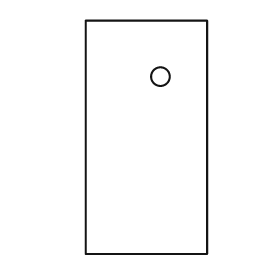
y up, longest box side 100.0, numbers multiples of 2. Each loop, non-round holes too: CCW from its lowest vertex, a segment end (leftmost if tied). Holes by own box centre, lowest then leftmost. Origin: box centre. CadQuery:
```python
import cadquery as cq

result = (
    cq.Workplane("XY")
    .moveTo(-26.0, -50.0)
    .lineTo(26.0, -50.0)
    .lineTo(26.0, 50.0)
    .lineTo(-26.0, 50.0)
    .close()
    .moveTo(6.0, 26.0)
    .circle(4.0)
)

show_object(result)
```